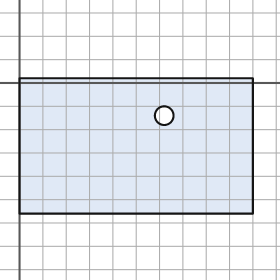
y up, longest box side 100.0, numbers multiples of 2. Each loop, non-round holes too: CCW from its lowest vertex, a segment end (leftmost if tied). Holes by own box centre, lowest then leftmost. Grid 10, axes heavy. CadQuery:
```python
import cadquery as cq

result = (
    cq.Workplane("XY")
    .moveTo(0.0, -56.0)
    .lineTo(100.0, -56.0)
    .lineTo(100.0, 2.0)
    .lineTo(0.0, 2.0)
    .close()
    .moveTo(62.0, -14.0)
    .circle(4.0)
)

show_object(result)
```